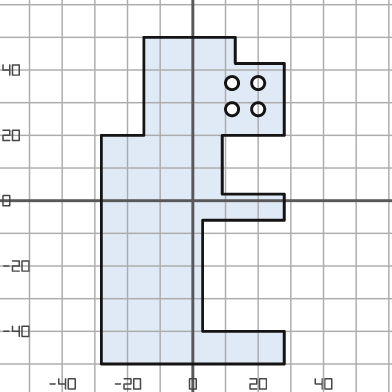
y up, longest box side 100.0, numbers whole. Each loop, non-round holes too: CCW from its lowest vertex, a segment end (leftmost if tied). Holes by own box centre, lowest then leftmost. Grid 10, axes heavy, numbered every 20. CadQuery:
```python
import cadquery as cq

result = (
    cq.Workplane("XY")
    .moveTo(-28.0, -50.0)
    .lineTo(28.0, -50.0)
    .lineTo(28.0, -40.0)
    .lineTo(3.0, -40.0)
    .lineTo(3.0, -6.0)
    .lineTo(28.0, -6.0)
    .lineTo(28.0, 2.0)
    .lineTo(9.0, 2.0)
    .lineTo(9.0, 20.0)
    .lineTo(28.0, 20.0)
    .lineTo(28.0, 42.0)
    .lineTo(13.0, 42.0)
    .lineTo(13.0, 50.0)
    .lineTo(-15.0, 50.0)
    .lineTo(-15.0, 20.0)
    .lineTo(-28.0, 20.0)
    .close()
    .moveTo(12.0, 28.0)
    .circle(2.0)
    .moveTo(20.0, 28.0)
    .circle(2.0)
    .moveTo(12.0, 36.0)
    .circle(2.0)
    .moveTo(20.0, 36.0)
    .circle(2.0)
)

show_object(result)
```